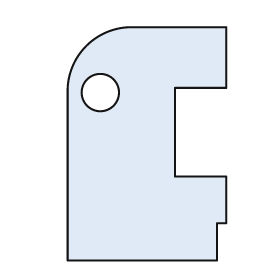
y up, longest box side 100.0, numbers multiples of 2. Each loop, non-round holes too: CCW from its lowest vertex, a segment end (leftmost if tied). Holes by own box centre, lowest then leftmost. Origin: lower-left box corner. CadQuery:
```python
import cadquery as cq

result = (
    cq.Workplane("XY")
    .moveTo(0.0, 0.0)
    .lineTo(64.0, 0.0)
    .lineTo(64.0, 16.0)
    .lineTo(68.0, 16.0)
    .lineTo(68.0, 36.0)
    .lineTo(46.0, 36.0)
    .lineTo(46.0, 74.0)
    .lineTo(68.0, 74.0)
    .lineTo(68.0, 100.0)
    .lineTo(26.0, 100.0)
    .threePointArc((8.0, 92.0), (0.0, 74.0))
    .close()
    .moveTo(14.0, 72.0)
    .circle(8.0)
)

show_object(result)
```